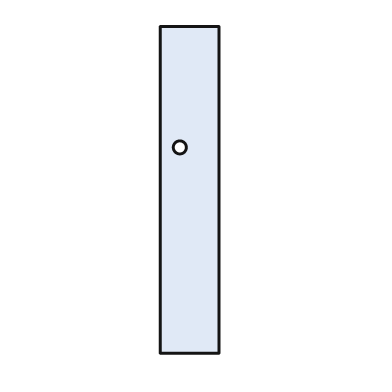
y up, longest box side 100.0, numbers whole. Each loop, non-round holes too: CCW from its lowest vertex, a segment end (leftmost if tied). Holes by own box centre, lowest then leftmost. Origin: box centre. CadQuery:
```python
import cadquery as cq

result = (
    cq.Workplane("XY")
    .moveTo(-9.0, -50.0)
    .lineTo(9.0, -50.0)
    .lineTo(9.0, 50.0)
    .lineTo(-9.0, 50.0)
    .close()
    .moveTo(-3.0, 13.0)
    .circle(2.0)
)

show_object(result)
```